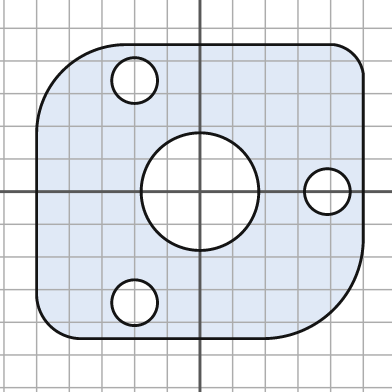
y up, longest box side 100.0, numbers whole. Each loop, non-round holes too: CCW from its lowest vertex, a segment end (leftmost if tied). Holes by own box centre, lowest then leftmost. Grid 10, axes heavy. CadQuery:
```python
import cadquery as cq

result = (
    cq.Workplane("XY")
    .moveTo(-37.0, -45.0)
    .lineTo(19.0, -45.0)
    .threePointArc((41.0, -36.0), (50.0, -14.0))
    .lineTo(50.0, 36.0)
    .threePointArc((47.0, 42.0), (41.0, 45.0))
    .lineTo(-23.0, 45.0)
    .threePointArc((-42.0, 37.0), (-50.0, 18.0))
    .lineTo(-50.0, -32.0)
    .threePointArc((-46.0, -41.0), (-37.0, -45.0))
    .close()
    .moveTo(-20.0, -34.0)
    .circle(7.0)
    .moveTo(0.0, 0.0)
    .circle(18.0)
    .moveTo(39.0, 0.0)
    .circle(7.0)
    .moveTo(-20.0, 34.0)
    .circle(7.0)
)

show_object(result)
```